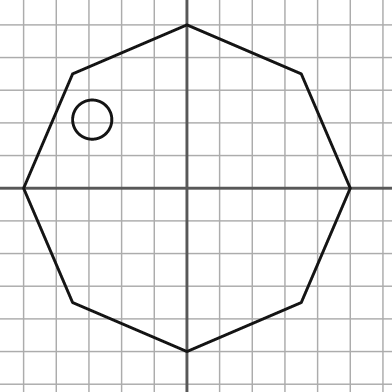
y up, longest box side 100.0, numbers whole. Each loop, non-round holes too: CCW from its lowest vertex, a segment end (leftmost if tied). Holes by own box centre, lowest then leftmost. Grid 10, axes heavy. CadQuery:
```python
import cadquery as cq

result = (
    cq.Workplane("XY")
    .moveTo(0.0, -50.0)
    .lineTo(35.0, -35.0)
    .lineTo(50.0, 0.0)
    .lineTo(35.0, 35.0)
    .lineTo(0.0, 50.0)
    .lineTo(-35.0, 35.0)
    .lineTo(-50.0, 0.0)
    .lineTo(-35.0, -35.0)
    .close()
    .moveTo(-29.0, 21.0)
    .circle(6.0)
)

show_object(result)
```